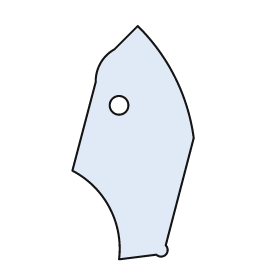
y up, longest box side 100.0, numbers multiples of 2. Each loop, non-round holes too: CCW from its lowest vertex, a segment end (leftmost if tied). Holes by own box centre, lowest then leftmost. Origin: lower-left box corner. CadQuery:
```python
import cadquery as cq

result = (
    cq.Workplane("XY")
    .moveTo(20.0, 0.0)
    .lineTo(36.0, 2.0)
    .threePointArc((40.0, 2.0), (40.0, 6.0))
    .lineTo(52.0, 52.0)
    .threePointArc((44.0, 78.0), (28.0, 100.0))
    .lineTo(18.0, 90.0)
    .threePointArc((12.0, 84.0), (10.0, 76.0))
    .lineTo(0.0, 38.0)
    .threePointArc((16.0, 22.0), (20.0, 0.0))
    .close()
    .moveTo(20.0, 66.0)
    .circle(4.0)
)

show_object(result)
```